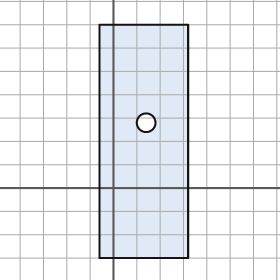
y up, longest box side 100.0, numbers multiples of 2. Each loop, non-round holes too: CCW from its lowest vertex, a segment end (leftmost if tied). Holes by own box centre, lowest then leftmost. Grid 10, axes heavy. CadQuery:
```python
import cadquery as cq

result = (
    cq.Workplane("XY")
    .moveTo(-6.0, -30.0)
    .lineTo(32.0, -30.0)
    .lineTo(32.0, 70.0)
    .lineTo(-6.0, 70.0)
    .close()
    .moveTo(14.0, 28.0)
    .circle(4.0)
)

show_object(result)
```